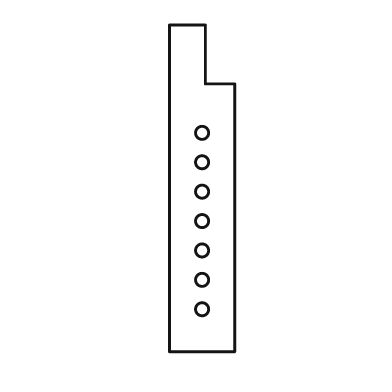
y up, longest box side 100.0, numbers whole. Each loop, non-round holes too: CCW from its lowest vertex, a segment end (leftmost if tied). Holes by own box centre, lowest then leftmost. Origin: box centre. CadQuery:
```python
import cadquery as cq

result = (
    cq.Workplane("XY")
    .moveTo(-10.0, -50.0)
    .lineTo(10.0, -50.0)
    .lineTo(10.0, 32.0)
    .lineTo(1.0, 32.0)
    .lineTo(1.0, 50.0)
    .lineTo(-10.0, 50.0)
    .close()
    .moveTo(0.0, -37.0)
    .circle(2.0)
    .moveTo(0.0, -28.0)
    .circle(2.0)
    .moveTo(0.0, -19.0)
    .circle(2.0)
    .moveTo(0.0, -10.0)
    .circle(2.0)
    .moveTo(0.0, -1.0)
    .circle(2.0)
    .moveTo(0.0, 8.0)
    .circle(2.0)
    .moveTo(0.0, 17.0)
    .circle(2.0)
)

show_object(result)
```